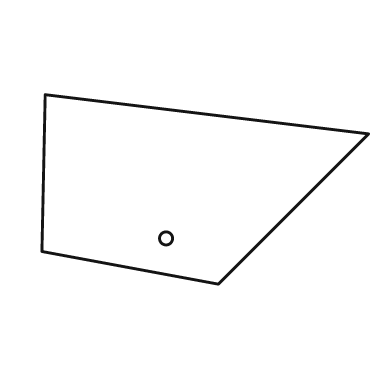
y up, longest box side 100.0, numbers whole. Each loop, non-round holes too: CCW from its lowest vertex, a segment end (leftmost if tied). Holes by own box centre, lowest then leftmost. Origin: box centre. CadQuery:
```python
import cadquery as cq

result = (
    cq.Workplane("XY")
    .moveTo(4.0, -29.0)
    .lineTo(50.0, 17.0)
    .lineTo(-49.0, 29.0)
    .lineTo(-50.0, -19.0)
    .close()
    .moveTo(-12.0, -15.0)
    .circle(2.0)
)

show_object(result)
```